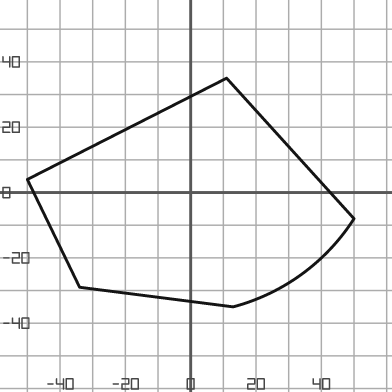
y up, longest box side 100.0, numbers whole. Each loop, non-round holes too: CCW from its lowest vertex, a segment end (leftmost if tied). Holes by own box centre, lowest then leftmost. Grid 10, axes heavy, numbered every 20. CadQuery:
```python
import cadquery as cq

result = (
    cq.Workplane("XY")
    .moveTo(13.0, -35.0)
    .threePointArc((34.0, -25.0), (50.0, -8.0))
    .lineTo(11.0, 35.0)
    .lineTo(-50.0, 4.0)
    .lineTo(-34.0, -29.0)
    .close()
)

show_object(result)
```